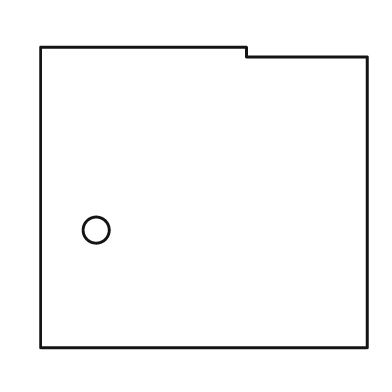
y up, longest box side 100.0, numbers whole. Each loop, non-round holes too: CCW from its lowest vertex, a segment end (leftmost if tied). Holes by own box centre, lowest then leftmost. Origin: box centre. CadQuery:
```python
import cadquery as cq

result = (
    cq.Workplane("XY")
    .moveTo(-50.0, -46.0)
    .lineTo(50.0, -46.0)
    .lineTo(50.0, 43.0)
    .lineTo(13.0, 43.0)
    .lineTo(13.0, 46.0)
    .lineTo(-50.0, 46.0)
    .close()
    .moveTo(-33.0, -10.0)
    .circle(4.0)
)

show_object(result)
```